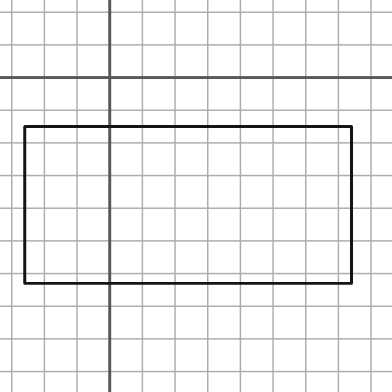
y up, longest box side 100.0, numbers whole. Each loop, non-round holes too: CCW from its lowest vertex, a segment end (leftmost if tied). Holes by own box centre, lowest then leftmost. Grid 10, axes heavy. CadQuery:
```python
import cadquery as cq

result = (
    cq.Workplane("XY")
    .moveTo(-26.0, -63.0)
    .lineTo(74.0, -63.0)
    .lineTo(74.0, -15.0)
    .lineTo(-26.0, -15.0)
    .close()
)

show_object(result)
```